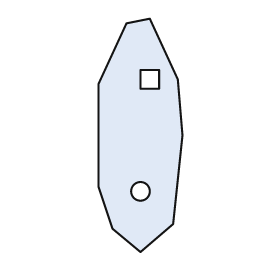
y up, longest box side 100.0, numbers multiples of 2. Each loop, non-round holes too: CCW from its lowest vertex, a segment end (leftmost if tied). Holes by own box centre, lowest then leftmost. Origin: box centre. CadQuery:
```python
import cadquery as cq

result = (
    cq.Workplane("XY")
    .moveTo(0.0, -50.0)
    .lineTo(14.0, -38.0)
    .lineTo(18.0, 0.0)
    .lineTo(16.0, 24.0)
    .lineTo(4.0, 50.0)
    .lineTo(-6.0, 48.0)
    .lineTo(-18.0, 22.0)
    .lineTo(-18.0, -22.0)
    .lineTo(-12.0, -40.0)
    .close()
    .moveTo(0.0, -24.0)
    .circle(4.0)
    .moveTo(0.0, 20.0)
    .lineTo(8.0, 20.0)
    .lineTo(8.0, 28.0)
    .lineTo(0.0, 28.0)
    .close()
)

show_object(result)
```